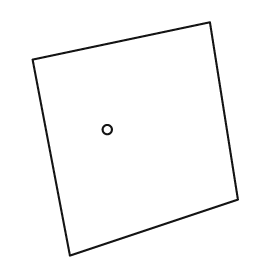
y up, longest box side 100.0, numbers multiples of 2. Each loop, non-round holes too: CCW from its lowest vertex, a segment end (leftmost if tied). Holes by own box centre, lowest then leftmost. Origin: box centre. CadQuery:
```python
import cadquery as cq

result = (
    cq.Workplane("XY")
    .moveTo(-28.0, -50.0)
    .lineTo(44.0, -26.0)
    .lineTo(32.0, 50.0)
    .lineTo(-44.0, 34.0)
    .close()
    .moveTo(-12.0, 4.0)
    .circle(2.0)
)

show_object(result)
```